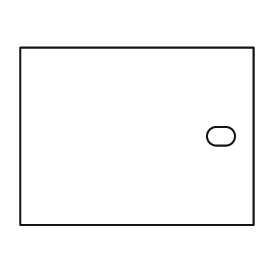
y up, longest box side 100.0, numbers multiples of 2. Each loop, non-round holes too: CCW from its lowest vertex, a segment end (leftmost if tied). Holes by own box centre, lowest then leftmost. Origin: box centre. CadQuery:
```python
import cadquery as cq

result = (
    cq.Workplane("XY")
    .moveTo(-50.0, -38.0)
    .lineTo(50.0, -38.0)
    .lineTo(50.0, 38.0)
    .lineTo(-50.0, 38.0)
    .close()
    .moveTo(34.0, -4.0)
    .lineTo(38.0, -4.0)
    .threePointArc((42.0, 0.0), (38.0, 4.0))
    .lineTo(34.0, 4.0)
    .threePointArc((30.0, 0.0), (34.0, -4.0))
    .close()
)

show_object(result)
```